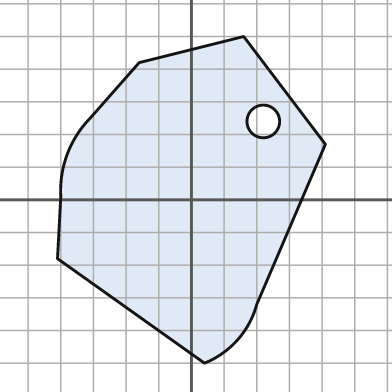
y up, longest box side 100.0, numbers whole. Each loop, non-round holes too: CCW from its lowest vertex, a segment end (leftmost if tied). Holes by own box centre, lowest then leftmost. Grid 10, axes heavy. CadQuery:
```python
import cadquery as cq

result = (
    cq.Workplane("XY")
    .moveTo(4.0, -50.0)
    .threePointArc((14.0, -43.0), (20.0, -32.0))
    .lineTo(41.0, 17.0)
    .lineTo(16.0, 50.0)
    .lineTo(-16.0, 42.0)
    .lineTo(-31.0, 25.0)
    .threePointArc((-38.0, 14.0), (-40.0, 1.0))
    .lineTo(-41.0, -18.0)
    .close()
    .moveTo(22.0, 24.0)
    .circle(5.0)
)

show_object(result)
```